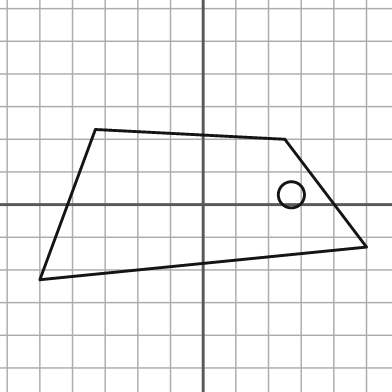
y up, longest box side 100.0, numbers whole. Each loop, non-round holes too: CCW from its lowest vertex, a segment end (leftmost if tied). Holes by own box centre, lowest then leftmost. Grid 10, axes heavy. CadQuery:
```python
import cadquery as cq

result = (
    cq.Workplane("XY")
    .moveTo(-50.0, -23.0)
    .lineTo(50.0, -13.0)
    .lineTo(25.0, 20.0)
    .lineTo(-33.0, 23.0)
    .close()
    .moveTo(27.0, 3.0)
    .circle(4.0)
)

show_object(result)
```